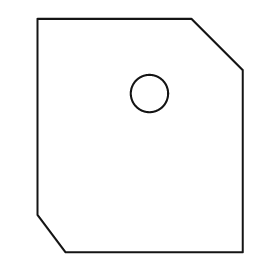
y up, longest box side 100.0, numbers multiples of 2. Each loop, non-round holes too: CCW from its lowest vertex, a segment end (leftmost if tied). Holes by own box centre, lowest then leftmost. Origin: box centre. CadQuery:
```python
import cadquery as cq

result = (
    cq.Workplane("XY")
    .moveTo(-32.0, -50.0)
    .lineTo(44.0, -50.0)
    .lineTo(44.0, 28.0)
    .lineTo(22.0, 50.0)
    .lineTo(-44.0, 50.0)
    .lineTo(-44.0, -34.0)
    .close()
    .moveTo(4.0, 18.0)
    .circle(8.0)
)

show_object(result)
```